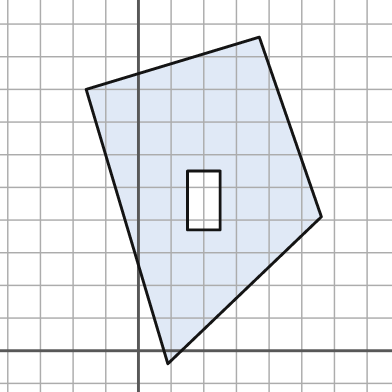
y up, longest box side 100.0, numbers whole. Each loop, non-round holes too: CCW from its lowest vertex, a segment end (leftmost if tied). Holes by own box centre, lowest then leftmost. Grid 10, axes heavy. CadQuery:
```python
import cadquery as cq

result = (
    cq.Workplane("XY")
    .moveTo(9.0, -4.0)
    .lineTo(56.0, 41.0)
    .lineTo(37.0, 96.0)
    .lineTo(-16.0, 80.0)
    .close()
    .moveTo(15.0, 37.0)
    .lineTo(25.0, 37.0)
    .lineTo(25.0, 55.0)
    .lineTo(15.0, 55.0)
    .close()
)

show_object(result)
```